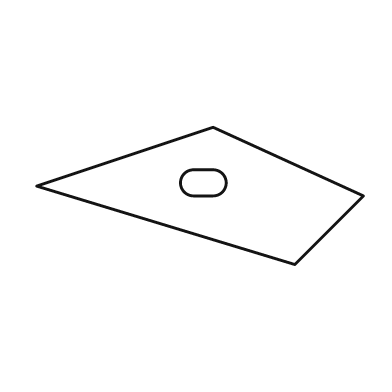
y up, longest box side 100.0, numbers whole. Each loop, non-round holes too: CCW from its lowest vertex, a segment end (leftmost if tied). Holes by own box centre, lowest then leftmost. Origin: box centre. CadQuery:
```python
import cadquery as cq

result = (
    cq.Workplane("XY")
    .moveTo(29.0, -21.0)
    .lineTo(50.0, 0.0)
    .lineTo(4.0, 21.0)
    .lineTo(-50.0, 3.0)
    .close()
    .moveTo(-2.0, 0.0)
    .lineTo(4.0, 0.0)
    .threePointArc((8.0, 4.0), (4.0, 8.0))
    .lineTo(-2.0, 8.0)
    .threePointArc((-6.0, 4.0), (-2.0, 0.0))
    .close()
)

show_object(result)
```